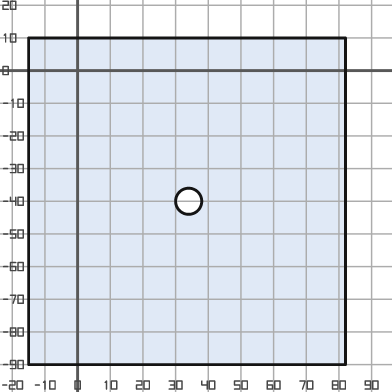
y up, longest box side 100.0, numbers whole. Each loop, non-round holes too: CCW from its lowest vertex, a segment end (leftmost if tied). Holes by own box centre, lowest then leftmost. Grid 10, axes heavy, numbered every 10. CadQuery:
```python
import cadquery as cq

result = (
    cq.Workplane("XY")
    .moveTo(-15.0, -90.0)
    .lineTo(82.0, -90.0)
    .lineTo(82.0, 10.0)
    .lineTo(-15.0, 10.0)
    .close()
    .moveTo(34.0, -40.0)
    .circle(4.0)
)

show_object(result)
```